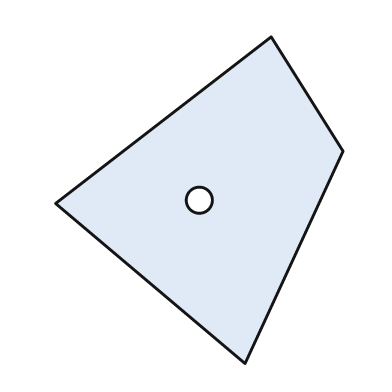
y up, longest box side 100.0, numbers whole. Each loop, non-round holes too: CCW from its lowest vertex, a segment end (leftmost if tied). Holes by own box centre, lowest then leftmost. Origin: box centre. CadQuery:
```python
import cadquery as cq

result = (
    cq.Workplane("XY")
    .moveTo(14.0, -50.0)
    .lineTo(44.0, 15.0)
    .lineTo(22.0, 50.0)
    .lineTo(-44.0, -1.0)
    .close()
    .moveTo(0.0, 0.0)
    .circle(4.0)
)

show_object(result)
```